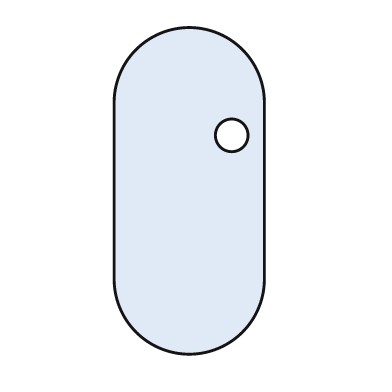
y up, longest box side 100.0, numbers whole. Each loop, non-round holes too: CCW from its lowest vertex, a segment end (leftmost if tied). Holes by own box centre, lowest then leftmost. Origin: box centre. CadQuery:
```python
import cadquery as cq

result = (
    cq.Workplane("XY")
    .moveTo(-23.0, -27.0)
    .threePointArc((0.0, -50.0), (23.0, -27.0))
    .lineTo(23.0, 27.0)
    .threePointArc((0.0, 50.0), (-23.0, 27.0))
    .close()
    .moveTo(13.0, 17.0)
    .circle(5.0)
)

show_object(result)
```